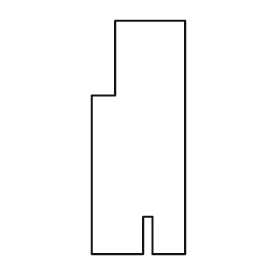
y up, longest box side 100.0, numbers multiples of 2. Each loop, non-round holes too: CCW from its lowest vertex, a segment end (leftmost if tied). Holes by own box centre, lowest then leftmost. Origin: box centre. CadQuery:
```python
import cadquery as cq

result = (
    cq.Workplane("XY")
    .moveTo(-20.0, -50.0)
    .lineTo(2.0, -50.0)
    .lineTo(2.0, -34.0)
    .lineTo(6.0, -34.0)
    .lineTo(6.0, -50.0)
    .lineTo(20.0, -50.0)
    .lineTo(20.0, 50.0)
    .lineTo(-10.0, 50.0)
    .lineTo(-10.0, 18.0)
    .lineTo(-20.0, 18.0)
    .close()
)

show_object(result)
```